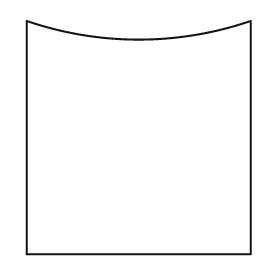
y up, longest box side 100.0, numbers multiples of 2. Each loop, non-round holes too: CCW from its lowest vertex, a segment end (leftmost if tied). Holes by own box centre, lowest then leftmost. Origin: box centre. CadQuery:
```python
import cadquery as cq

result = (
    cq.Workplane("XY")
    .moveTo(-48.0, -50.0)
    .lineTo(48.0, -50.0)
    .lineTo(48.0, 50.0)
    .threePointArc((0.0, 42.0), (-48.0, 50.0))
    .close()
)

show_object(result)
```